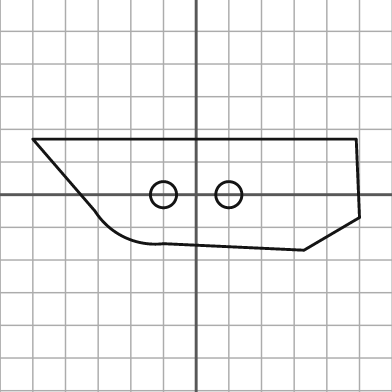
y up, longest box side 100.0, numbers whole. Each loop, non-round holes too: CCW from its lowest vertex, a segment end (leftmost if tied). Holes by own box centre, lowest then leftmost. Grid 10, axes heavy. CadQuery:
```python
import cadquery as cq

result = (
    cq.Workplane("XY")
    .moveTo(33.0, -17.0)
    .lineTo(50.0, -7.0)
    .lineTo(49.0, 17.0)
    .lineTo(-50.0, 17.0)
    .lineTo(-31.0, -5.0)
    .threePointArc((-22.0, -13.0), (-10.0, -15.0))
    .close()
    .moveTo(-10.0, 0.0)
    .circle(4.0)
    .moveTo(10.0, 0.0)
    .circle(4.0)
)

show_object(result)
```